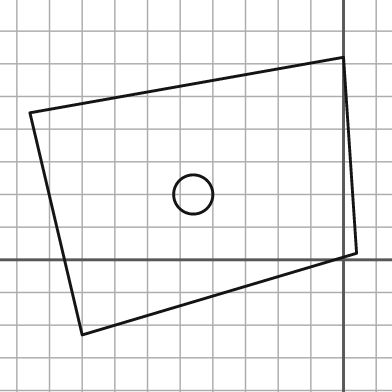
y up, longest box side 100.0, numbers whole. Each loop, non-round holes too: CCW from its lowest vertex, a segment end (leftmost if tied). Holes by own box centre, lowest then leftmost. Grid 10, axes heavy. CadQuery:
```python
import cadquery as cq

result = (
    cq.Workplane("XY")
    .moveTo(-80.0, -23.0)
    .lineTo(4.0, 2.0)
    .lineTo(0.0, 62.0)
    .lineTo(-96.0, 45.0)
    .close()
    .moveTo(-46.0, 20.0)
    .circle(6.0)
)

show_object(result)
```